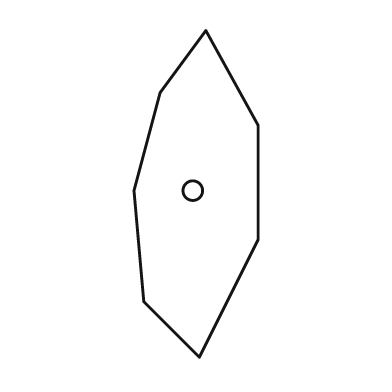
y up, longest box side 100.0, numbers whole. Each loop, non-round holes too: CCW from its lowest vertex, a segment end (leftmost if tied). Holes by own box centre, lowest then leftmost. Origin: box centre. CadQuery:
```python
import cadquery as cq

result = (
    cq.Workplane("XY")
    .moveTo(1.0, -50.0)
    .lineTo(19.0, -14.0)
    .lineTo(19.0, 21.0)
    .lineTo(3.0, 50.0)
    .lineTo(-11.0, 31.0)
    .lineTo(-19.0, 1.0)
    .lineTo(-16.0, -33.0)
    .close()
    .moveTo(-1.0, 1.0)
    .circle(3.0)
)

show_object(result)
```